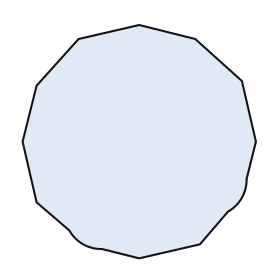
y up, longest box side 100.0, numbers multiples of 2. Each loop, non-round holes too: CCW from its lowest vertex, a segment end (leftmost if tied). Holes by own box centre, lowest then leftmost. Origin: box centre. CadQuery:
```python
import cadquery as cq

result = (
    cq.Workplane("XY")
    .moveTo(0.0, -50.0)
    .lineTo(26.0, -44.0)
    .lineTo(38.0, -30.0)
    .threePointArc((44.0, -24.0), (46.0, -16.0))
    .lineTo(50.0, 0.0)
    .lineTo(44.0, 26.0)
    .lineTo(24.0, 44.0)
    .lineTo(0.0, 50.0)
    .lineTo(-26.0, 44.0)
    .lineTo(-44.0, 24.0)
    .lineTo(-50.0, 0.0)
    .lineTo(-44.0, -26.0)
    .lineTo(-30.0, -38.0)
    .threePointArc((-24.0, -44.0), (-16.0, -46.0))
    .close()
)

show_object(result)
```